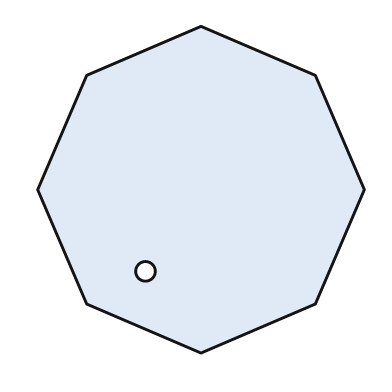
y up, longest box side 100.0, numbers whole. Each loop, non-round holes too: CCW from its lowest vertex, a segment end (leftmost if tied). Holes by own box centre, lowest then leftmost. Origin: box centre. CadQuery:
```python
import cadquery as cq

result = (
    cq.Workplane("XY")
    .moveTo(0.0, -50.0)
    .lineTo(35.0, -35.0)
    .lineTo(50.0, 0.0)
    .lineTo(35.0, 35.0)
    .lineTo(0.0, 50.0)
    .lineTo(-35.0, 35.0)
    .lineTo(-50.0, 0.0)
    .lineTo(-35.0, -35.0)
    .close()
    .moveTo(-17.0, -25.0)
    .circle(3.0)
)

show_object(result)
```